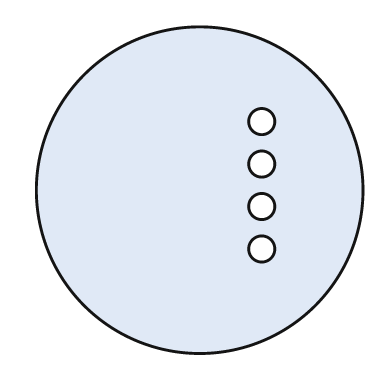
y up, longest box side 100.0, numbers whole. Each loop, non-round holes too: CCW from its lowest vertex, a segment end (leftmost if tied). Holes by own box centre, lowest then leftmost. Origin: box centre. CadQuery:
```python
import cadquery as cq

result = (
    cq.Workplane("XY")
    .moveTo(0.0, 0.0)
    .circle(50.0)
    .moveTo(19.0, -18.0)
    .circle(4.0)
    .moveTo(19.0, -5.0)
    .circle(4.0)
    .moveTo(19.0, 8.0)
    .circle(4.0)
    .moveTo(19.0, 21.0)
    .circle(4.0)
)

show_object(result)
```